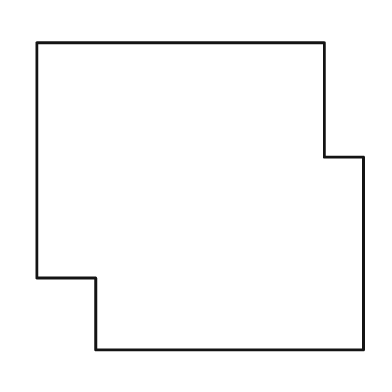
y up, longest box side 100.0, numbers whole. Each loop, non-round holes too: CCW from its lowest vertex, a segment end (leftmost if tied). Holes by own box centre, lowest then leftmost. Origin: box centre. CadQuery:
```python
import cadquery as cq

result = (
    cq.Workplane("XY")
    .moveTo(-32.0, -47.0)
    .lineTo(50.0, -47.0)
    .lineTo(50.0, 12.0)
    .lineTo(38.0, 12.0)
    .lineTo(38.0, 47.0)
    .lineTo(-50.0, 47.0)
    .lineTo(-50.0, -25.0)
    .lineTo(-32.0, -25.0)
    .close()
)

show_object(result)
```